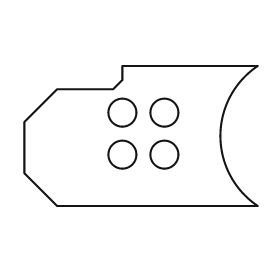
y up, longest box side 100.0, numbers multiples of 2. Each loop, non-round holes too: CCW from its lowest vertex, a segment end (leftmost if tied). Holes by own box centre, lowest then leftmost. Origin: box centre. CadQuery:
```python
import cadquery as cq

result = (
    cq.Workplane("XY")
    .moveTo(-36.0, -30.0)
    .lineTo(50.0, -30.0)
    .threePointArc((34.0, 0.0), (50.0, 30.0))
    .lineTo(-8.0, 30.0)
    .lineTo(-8.0, 24.0)
    .lineTo(-12.0, 20.0)
    .lineTo(-36.0, 20.0)
    .lineTo(-50.0, 6.0)
    .lineTo(-50.0, -16.0)
    .close()
    .moveTo(-8.0, -8.0)
    .circle(6.0)
    .moveTo(10.0, -8.0)
    .circle(6.0)
    .moveTo(-8.0, 10.0)
    .circle(6.0)
    .moveTo(10.0, 10.0)
    .circle(6.0)
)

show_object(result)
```